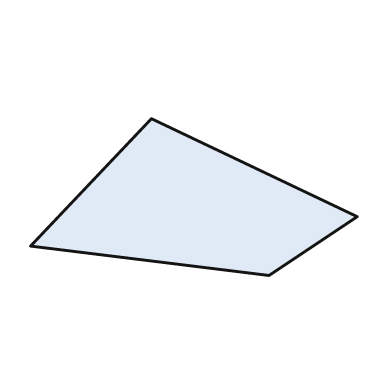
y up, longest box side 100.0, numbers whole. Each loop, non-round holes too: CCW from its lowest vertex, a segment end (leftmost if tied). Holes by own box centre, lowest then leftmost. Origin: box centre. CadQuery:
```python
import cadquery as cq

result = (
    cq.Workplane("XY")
    .moveTo(23.0, -24.0)
    .lineTo(50.0, -6.0)
    .lineTo(-13.0, 24.0)
    .lineTo(-50.0, -15.0)
    .close()
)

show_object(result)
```